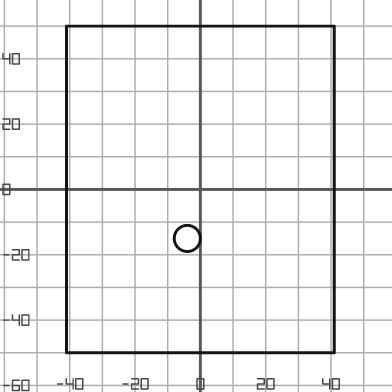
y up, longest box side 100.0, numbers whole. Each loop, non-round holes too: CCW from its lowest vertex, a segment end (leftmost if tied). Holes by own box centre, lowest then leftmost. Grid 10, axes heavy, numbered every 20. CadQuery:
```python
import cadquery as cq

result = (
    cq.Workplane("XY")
    .moveTo(-41.0, -50.0)
    .lineTo(41.0, -50.0)
    .lineTo(41.0, 50.0)
    .lineTo(-41.0, 50.0)
    .close()
    .moveTo(-4.0, -15.0)
    .circle(4.0)
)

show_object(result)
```